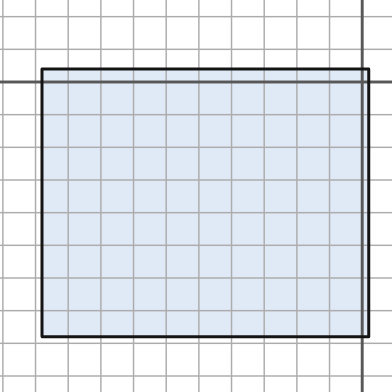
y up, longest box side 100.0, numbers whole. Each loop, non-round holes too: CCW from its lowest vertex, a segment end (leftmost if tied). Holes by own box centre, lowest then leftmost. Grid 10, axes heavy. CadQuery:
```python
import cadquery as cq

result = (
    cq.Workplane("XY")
    .moveTo(-98.0, -78.0)
    .lineTo(2.0, -78.0)
    .lineTo(2.0, 4.0)
    .lineTo(-98.0, 4.0)
    .close()
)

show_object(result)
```